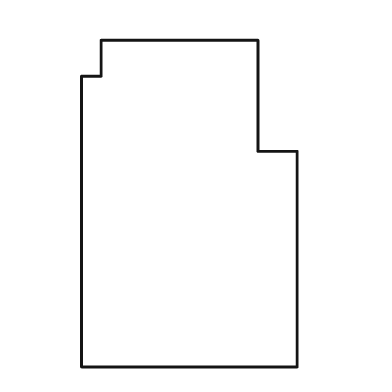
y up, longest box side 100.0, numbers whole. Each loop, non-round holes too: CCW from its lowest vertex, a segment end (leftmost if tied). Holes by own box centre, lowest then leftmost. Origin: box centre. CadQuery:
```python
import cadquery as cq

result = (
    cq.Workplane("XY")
    .moveTo(-33.0, -50.0)
    .lineTo(33.0, -50.0)
    .lineTo(33.0, 16.0)
    .lineTo(21.0, 16.0)
    .lineTo(21.0, 50.0)
    .lineTo(-27.0, 50.0)
    .lineTo(-27.0, 39.0)
    .lineTo(-33.0, 39.0)
    .close()
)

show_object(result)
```